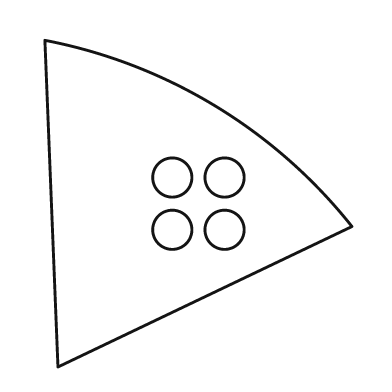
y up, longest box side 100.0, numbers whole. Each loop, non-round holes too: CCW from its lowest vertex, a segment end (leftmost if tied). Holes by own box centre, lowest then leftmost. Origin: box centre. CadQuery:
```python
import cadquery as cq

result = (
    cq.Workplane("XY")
    .moveTo(-43.0, -50.0)
    .lineTo(47.0, -7.0)
    .threePointArc((5.0, 30.0), (-47.0, 50.0))
    .close()
    .moveTo(-8.0, -8.0)
    .circle(6.0)
    .moveTo(8.0, -8.0)
    .circle(6.0)
    .moveTo(-8.0, 8.0)
    .circle(6.0)
    .moveTo(8.0, 8.0)
    .circle(6.0)
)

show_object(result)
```